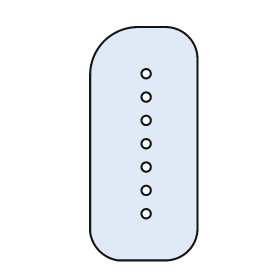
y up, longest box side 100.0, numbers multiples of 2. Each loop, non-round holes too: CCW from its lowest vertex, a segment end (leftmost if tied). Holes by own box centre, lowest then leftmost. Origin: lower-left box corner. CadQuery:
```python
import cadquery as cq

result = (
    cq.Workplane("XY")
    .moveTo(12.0, 0.0)
    .lineTo(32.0, 0.0)
    .threePointArc((42.0, 4.0), (46.0, 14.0))
    .lineTo(46.0, 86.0)
    .threePointArc((42.0, 96.0), (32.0, 100.0))
    .lineTo(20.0, 100.0)
    .threePointArc((6.0, 94.0), (0.0, 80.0))
    .lineTo(0.0, 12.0)
    .threePointArc((4.0, 4.0), (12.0, 0.0))
    .close()
    .moveTo(24.0, 20.0)
    .circle(2.0)
    .moveTo(24.0, 30.0)
    .circle(2.0)
    .moveTo(24.0, 40.0)
    .circle(2.0)
    .moveTo(24.0, 50.0)
    .circle(2.0)
    .moveTo(24.0, 60.0)
    .circle(2.0)
    .moveTo(24.0, 70.0)
    .circle(2.0)
    .moveTo(24.0, 80.0)
    .circle(2.0)
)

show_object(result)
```